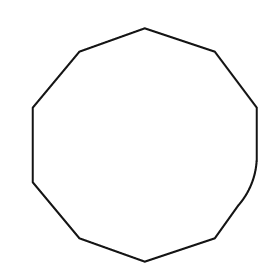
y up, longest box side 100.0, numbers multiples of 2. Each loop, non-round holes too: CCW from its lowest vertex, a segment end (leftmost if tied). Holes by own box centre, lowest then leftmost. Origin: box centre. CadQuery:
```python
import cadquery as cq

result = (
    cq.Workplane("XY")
    .moveTo(0.0, -50.0)
    .lineTo(30.0, -40.0)
    .lineTo(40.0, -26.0)
    .threePointArc((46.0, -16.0), (48.0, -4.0))
    .lineTo(48.0, 16.0)
    .lineTo(30.0, 40.0)
    .lineTo(0.0, 50.0)
    .lineTo(-28.0, 40.0)
    .lineTo(-48.0, 16.0)
    .lineTo(-48.0, -16.0)
    .lineTo(-28.0, -40.0)
    .close()
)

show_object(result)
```